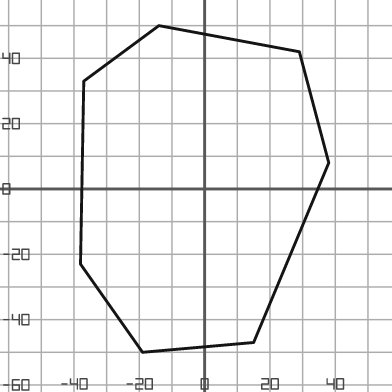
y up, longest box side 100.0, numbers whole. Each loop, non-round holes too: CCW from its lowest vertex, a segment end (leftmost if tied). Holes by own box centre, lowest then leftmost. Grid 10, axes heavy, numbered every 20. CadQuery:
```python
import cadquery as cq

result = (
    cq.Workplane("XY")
    .moveTo(-19.0, -50.0)
    .lineTo(15.0, -47.0)
    .lineTo(38.0, 8.0)
    .lineTo(29.0, 42.0)
    .lineTo(-14.0, 50.0)
    .lineTo(-37.0, 33.0)
    .lineTo(-38.0, -23.0)
    .close()
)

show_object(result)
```